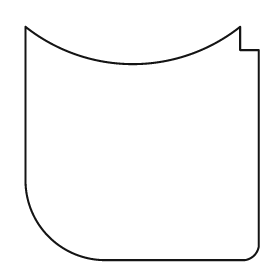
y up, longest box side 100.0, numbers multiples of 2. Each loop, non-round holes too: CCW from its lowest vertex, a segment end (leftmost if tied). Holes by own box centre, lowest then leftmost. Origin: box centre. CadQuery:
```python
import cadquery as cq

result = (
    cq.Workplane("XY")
    .moveTo(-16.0, -50.0)
    .lineTo(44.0, -50.0)
    .threePointArc((48.0, -48.0), (50.0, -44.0))
    .lineTo(50.0, 40.0)
    .lineTo(42.0, 40.0)
    .lineTo(42.0, 50.0)
    .threePointArc((-4.0, 34.0), (-50.0, 50.0))
    .lineTo(-50.0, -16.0)
    .threePointArc((-40.0, -40.0), (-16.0, -50.0))
    .close()
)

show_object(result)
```